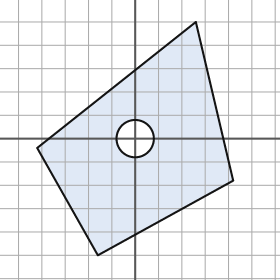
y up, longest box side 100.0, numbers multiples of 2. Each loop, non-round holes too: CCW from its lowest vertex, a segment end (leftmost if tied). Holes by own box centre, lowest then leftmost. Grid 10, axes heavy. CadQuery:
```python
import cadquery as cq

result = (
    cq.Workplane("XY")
    .moveTo(-16.0, -50.0)
    .lineTo(42.0, -18.0)
    .lineTo(26.0, 50.0)
    .lineTo(-42.0, -4.0)
    .close()
    .moveTo(0.0, 0.0)
    .circle(8.0)
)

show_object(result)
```